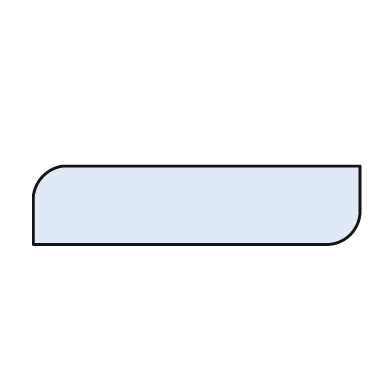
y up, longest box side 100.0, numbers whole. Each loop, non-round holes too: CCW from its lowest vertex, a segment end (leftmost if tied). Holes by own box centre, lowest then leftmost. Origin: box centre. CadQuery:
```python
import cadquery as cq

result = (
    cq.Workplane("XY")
    .moveTo(-50.0, -12.0)
    .lineTo(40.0, -12.0)
    .threePointArc((47.0, -9.0), (50.0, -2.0))
    .lineTo(50.0, 12.0)
    .lineTo(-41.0, 12.0)
    .threePointArc((-47.0, 9.0), (-50.0, 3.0))
    .close()
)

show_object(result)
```